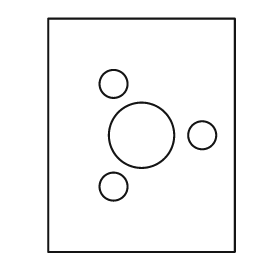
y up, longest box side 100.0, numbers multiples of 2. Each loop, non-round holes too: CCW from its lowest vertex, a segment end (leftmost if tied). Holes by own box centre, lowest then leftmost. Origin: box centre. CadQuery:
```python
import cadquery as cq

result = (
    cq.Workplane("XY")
    .moveTo(-40.0, -50.0)
    .lineTo(40.0, -50.0)
    .lineTo(40.0, 50.0)
    .lineTo(-40.0, 50.0)
    .close()
    .moveTo(-12.0, -22.0)
    .circle(6.0)
    .moveTo(0.0, 0.0)
    .circle(14.0)
    .moveTo(26.0, 0.0)
    .circle(6.0)
    .moveTo(-12.0, 22.0)
    .circle(6.0)
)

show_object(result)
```